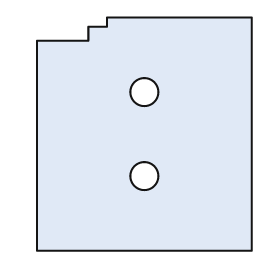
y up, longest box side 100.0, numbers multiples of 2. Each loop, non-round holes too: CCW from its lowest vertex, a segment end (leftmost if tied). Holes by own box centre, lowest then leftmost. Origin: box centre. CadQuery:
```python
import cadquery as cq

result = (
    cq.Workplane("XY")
    .moveTo(-46.0, -50.0)
    .lineTo(46.0, -50.0)
    .lineTo(46.0, 50.0)
    .lineTo(-16.0, 50.0)
    .lineTo(-16.0, 46.0)
    .lineTo(-24.0, 46.0)
    .lineTo(-24.0, 40.0)
    .lineTo(-46.0, 40.0)
    .close()
    .moveTo(0.0, -18.0)
    .circle(6.0)
    .moveTo(0.0, 18.0)
    .circle(6.0)
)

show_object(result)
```